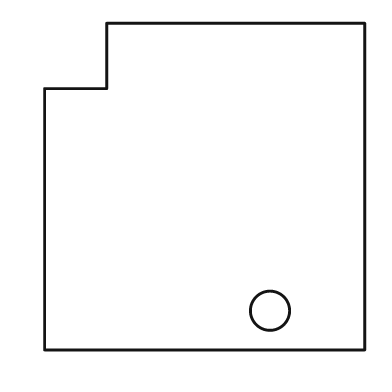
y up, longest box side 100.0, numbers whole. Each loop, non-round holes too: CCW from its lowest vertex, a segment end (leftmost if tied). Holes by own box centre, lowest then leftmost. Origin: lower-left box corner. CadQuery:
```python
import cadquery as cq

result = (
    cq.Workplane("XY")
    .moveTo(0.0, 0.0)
    .lineTo(98.0, 0.0)
    .lineTo(98.0, 100.0)
    .lineTo(19.0, 100.0)
    .lineTo(19.0, 80.0)
    .lineTo(0.0, 80.0)
    .close()
    .moveTo(69.0, 12.0)
    .circle(6.0)
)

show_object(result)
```